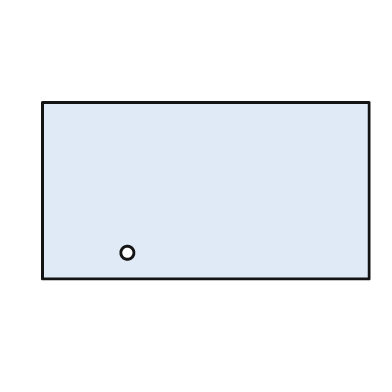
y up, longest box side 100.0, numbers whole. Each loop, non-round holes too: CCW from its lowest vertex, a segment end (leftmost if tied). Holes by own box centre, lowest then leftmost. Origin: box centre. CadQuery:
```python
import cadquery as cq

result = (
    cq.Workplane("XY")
    .moveTo(-50.0, -27.0)
    .lineTo(50.0, -27.0)
    .lineTo(50.0, 27.0)
    .lineTo(-50.0, 27.0)
    .close()
    .moveTo(-24.0, -19.0)
    .circle(2.0)
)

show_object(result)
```